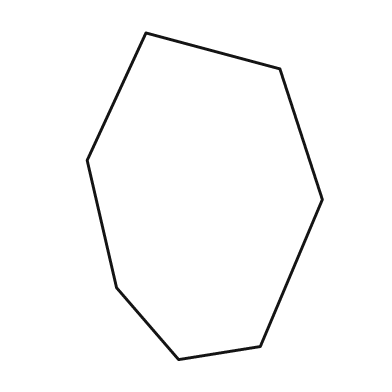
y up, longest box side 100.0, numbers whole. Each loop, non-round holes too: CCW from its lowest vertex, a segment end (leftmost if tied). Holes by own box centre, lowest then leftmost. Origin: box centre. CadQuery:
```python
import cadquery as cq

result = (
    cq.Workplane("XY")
    .moveTo(-8.0, -50.0)
    .lineTo(17.0, -46.0)
    .lineTo(36.0, -1.0)
    .lineTo(23.0, 39.0)
    .lineTo(-18.0, 50.0)
    .lineTo(-36.0, 11.0)
    .lineTo(-27.0, -28.0)
    .close()
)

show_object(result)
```